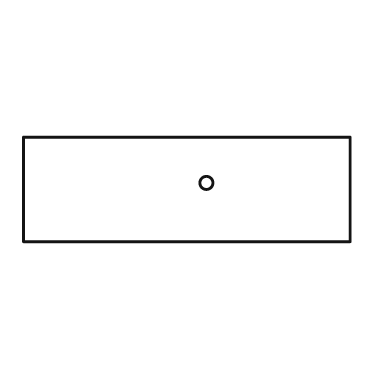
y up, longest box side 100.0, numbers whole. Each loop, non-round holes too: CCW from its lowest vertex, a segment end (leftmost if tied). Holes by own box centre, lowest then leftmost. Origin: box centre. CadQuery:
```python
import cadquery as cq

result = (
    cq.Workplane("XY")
    .moveTo(-50.0, -16.0)
    .lineTo(50.0, -16.0)
    .lineTo(50.0, 16.0)
    .lineTo(-50.0, 16.0)
    .close()
    .moveTo(6.0, 2.0)
    .circle(2.0)
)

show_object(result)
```